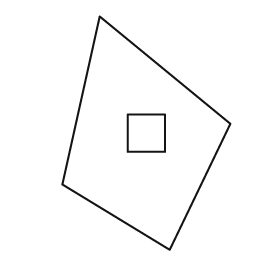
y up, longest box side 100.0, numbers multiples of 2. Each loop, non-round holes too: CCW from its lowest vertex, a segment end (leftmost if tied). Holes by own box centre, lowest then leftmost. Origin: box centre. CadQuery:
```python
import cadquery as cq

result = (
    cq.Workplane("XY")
    .moveTo(10.0, -50.0)
    .lineTo(36.0, 4.0)
    .lineTo(-20.0, 50.0)
    .lineTo(-36.0, -22.0)
    .close()
    .moveTo(-8.0, -8.0)
    .lineTo(8.0, -8.0)
    .lineTo(8.0, 8.0)
    .lineTo(-8.0, 8.0)
    .close()
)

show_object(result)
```